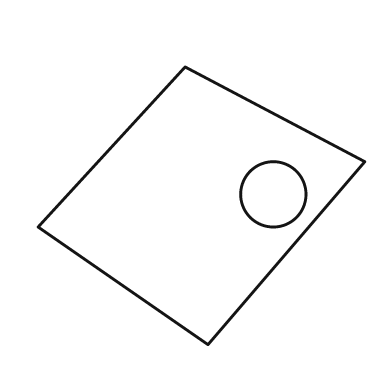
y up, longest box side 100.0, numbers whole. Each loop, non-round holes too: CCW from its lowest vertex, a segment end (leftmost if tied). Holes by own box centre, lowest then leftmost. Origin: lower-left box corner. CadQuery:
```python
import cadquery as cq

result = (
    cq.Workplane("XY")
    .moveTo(52.0, 0.0)
    .lineTo(100.0, 56.0)
    .lineTo(45.0, 85.0)
    .lineTo(0.0, 36.0)
    .close()
    .moveTo(72.0, 46.0)
    .circle(10.0)
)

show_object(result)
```